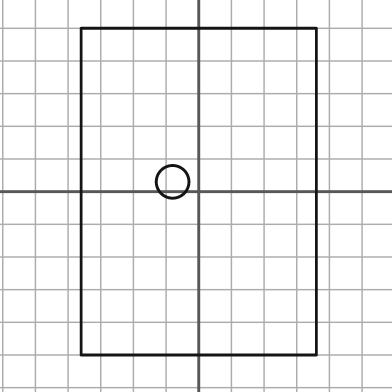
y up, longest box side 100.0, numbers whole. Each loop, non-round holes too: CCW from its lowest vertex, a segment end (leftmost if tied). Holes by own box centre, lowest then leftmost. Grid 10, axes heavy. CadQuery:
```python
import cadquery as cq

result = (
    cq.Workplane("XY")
    .moveTo(-36.0, -50.0)
    .lineTo(36.0, -50.0)
    .lineTo(36.0, 50.0)
    .lineTo(-36.0, 50.0)
    .close()
    .moveTo(-8.0, 3.0)
    .circle(5.0)
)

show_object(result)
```